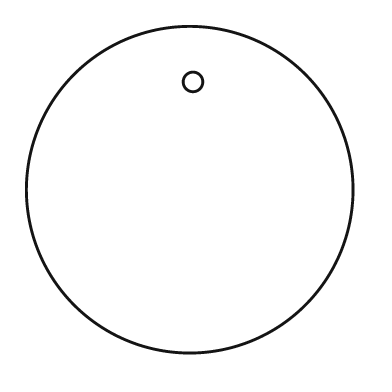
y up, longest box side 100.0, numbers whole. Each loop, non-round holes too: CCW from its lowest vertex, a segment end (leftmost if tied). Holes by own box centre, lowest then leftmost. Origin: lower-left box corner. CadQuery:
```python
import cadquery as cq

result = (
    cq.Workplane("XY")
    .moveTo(50.0, 50.0)
    .circle(50.0)
    .moveTo(51.0, 83.0)
    .circle(3.0)
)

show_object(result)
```